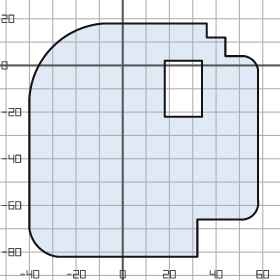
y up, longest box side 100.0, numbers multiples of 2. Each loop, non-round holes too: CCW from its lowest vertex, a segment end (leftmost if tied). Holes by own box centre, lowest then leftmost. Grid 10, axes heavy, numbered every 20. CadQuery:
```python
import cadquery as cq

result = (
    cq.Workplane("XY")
    .moveTo(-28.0, -82.0)
    .lineTo(32.0, -82.0)
    .lineTo(32.0, -66.0)
    .lineTo(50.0, -66.0)
    .threePointArc((56.0, -64.0), (58.0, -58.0))
    .lineTo(58.0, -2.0)
    .threePointArc((56.0, 2.0), (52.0, 4.0))
    .lineTo(44.0, 4.0)
    .lineTo(44.0, 12.0)
    .lineTo(36.0, 12.0)
    .lineTo(36.0, 18.0)
    .lineTo(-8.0, 18.0)
    .threePointArc((-30.0, 8.0), (-40.0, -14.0))
    .lineTo(-40.0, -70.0)
    .threePointArc((-36.0, -78.0), (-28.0, -82.0))
    .close()
    .moveTo(18.0, -22.0)
    .lineTo(34.0, -22.0)
    .lineTo(34.0, 2.0)
    .lineTo(18.0, 2.0)
    .close()
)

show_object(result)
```